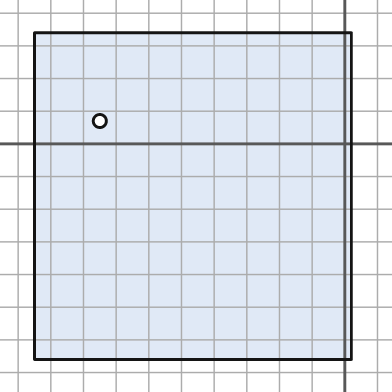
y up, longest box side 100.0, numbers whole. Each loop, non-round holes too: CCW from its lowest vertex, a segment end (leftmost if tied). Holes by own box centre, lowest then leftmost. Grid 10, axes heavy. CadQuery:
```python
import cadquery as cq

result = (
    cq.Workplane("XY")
    .moveTo(-95.0, -66.0)
    .lineTo(2.0, -66.0)
    .lineTo(2.0, 34.0)
    .lineTo(-95.0, 34.0)
    .close()
    .moveTo(-75.0, 7.0)
    .circle(2.0)
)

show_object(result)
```